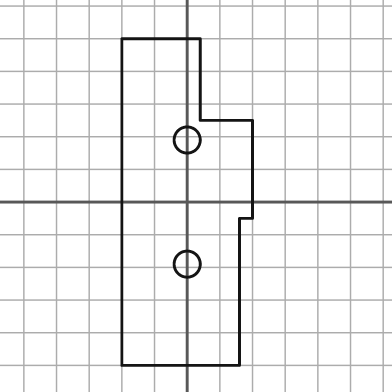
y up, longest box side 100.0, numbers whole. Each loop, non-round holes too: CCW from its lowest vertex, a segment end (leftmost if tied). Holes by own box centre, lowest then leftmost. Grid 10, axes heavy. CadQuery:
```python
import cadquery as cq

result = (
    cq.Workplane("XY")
    .moveTo(-20.0, -50.0)
    .lineTo(16.0, -50.0)
    .lineTo(16.0, -5.0)
    .lineTo(20.0, -5.0)
    .lineTo(20.0, 25.0)
    .lineTo(4.0, 25.0)
    .lineTo(4.0, 50.0)
    .lineTo(-20.0, 50.0)
    .close()
    .moveTo(0.0, -19.0)
    .circle(4.0)
    .moveTo(0.0, 19.0)
    .circle(4.0)
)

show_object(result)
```